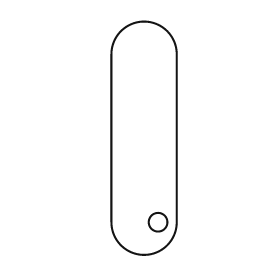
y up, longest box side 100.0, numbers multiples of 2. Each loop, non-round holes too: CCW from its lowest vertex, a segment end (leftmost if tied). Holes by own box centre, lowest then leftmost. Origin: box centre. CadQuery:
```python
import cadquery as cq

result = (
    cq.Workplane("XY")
    .moveTo(-14.0, -36.0)
    .threePointArc((0.0, -50.0), (14.0, -36.0))
    .lineTo(14.0, 36.0)
    .threePointArc((0.0, 50.0), (-14.0, 36.0))
    .close()
    .moveTo(6.0, -36.0)
    .circle(4.0)
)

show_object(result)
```